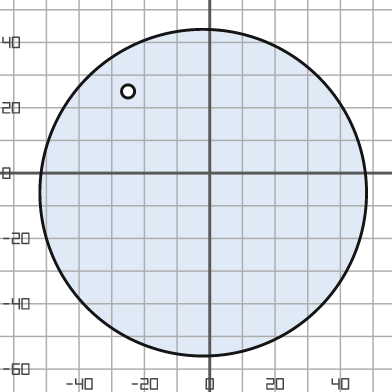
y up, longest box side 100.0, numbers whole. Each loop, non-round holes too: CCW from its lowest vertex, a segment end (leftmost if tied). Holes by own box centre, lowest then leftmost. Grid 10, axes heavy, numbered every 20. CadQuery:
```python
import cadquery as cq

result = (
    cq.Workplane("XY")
    .moveTo(-2.0, -6.0)
    .circle(50.0)
    .moveTo(-25.0, 25.0)
    .circle(2.0)
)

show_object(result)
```